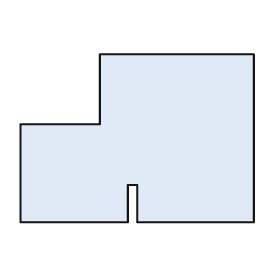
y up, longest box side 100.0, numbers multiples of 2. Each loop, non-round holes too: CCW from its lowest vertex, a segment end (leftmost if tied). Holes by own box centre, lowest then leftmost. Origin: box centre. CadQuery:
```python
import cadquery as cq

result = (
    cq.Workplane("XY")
    .moveTo(-50.0, -36.0)
    .lineTo(-4.0, -36.0)
    .lineTo(-4.0, -20.0)
    .lineTo(0.0, -20.0)
    .lineTo(0.0, -36.0)
    .lineTo(50.0, -36.0)
    .lineTo(50.0, 36.0)
    .lineTo(-16.0, 36.0)
    .lineTo(-16.0, 6.0)
    .lineTo(-50.0, 6.0)
    .close()
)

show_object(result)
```